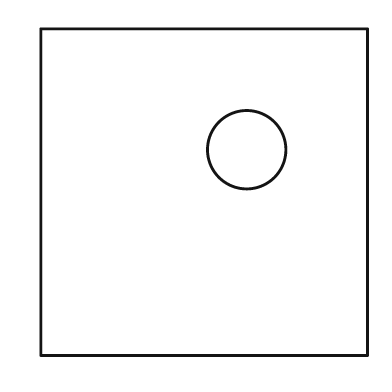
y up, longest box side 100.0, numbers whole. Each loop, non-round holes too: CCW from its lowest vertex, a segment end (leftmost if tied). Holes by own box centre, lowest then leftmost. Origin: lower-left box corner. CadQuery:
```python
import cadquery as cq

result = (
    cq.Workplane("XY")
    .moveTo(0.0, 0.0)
    .lineTo(100.0, 0.0)
    .lineTo(100.0, 100.0)
    .lineTo(0.0, 100.0)
    .close()
    .moveTo(63.0, 63.0)
    .circle(12.0)
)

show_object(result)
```